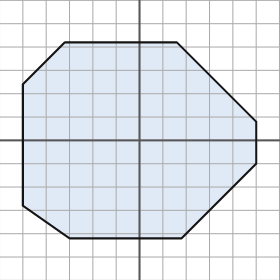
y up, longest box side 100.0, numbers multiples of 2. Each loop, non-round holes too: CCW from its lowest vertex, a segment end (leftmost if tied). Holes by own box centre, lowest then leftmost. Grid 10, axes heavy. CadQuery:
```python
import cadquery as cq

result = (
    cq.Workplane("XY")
    .moveTo(-30.0, -42.0)
    .lineTo(18.0, -42.0)
    .lineTo(50.0, -10.0)
    .lineTo(50.0, 8.0)
    .lineTo(16.0, 42.0)
    .lineTo(-32.0, 42.0)
    .lineTo(-50.0, 24.0)
    .lineTo(-50.0, -28.0)
    .close()
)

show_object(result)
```